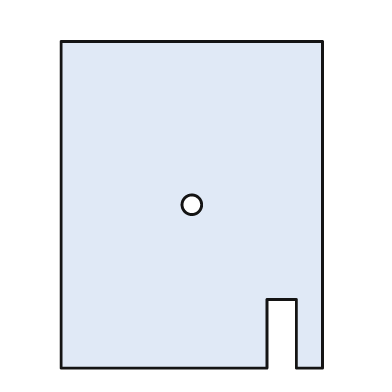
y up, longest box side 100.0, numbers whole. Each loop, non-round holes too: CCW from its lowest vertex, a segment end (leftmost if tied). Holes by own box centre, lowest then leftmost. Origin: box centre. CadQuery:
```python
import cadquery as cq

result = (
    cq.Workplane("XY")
    .moveTo(-40.0, -50.0)
    .lineTo(23.0, -50.0)
    .lineTo(23.0, -29.0)
    .lineTo(32.0, -29.0)
    .lineTo(32.0, -50.0)
    .lineTo(40.0, -50.0)
    .lineTo(40.0, 50.0)
    .lineTo(-40.0, 50.0)
    .close()
    .moveTo(0.0, 0.0)
    .circle(3.0)
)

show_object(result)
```